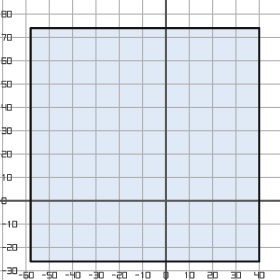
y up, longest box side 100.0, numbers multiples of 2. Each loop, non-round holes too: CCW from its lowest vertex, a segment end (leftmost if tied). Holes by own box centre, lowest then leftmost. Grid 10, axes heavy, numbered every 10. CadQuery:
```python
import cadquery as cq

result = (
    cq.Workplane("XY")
    .moveTo(-58.0, -26.0)
    .lineTo(40.0, -26.0)
    .lineTo(40.0, 74.0)
    .lineTo(-58.0, 74.0)
    .close()
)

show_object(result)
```